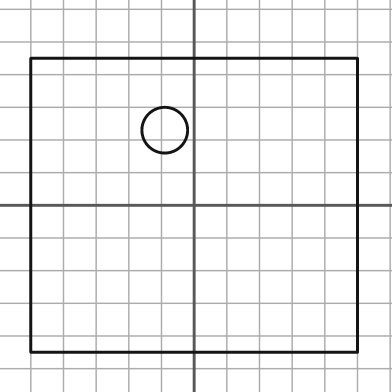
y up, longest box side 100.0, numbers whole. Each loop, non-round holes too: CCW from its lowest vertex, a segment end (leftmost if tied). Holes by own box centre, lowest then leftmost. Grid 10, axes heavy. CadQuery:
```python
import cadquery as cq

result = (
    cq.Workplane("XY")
    .moveTo(-50.0, -45.0)
    .lineTo(50.0, -45.0)
    .lineTo(50.0, 45.0)
    .lineTo(-50.0, 45.0)
    .close()
    .moveTo(-9.0, 23.0)
    .circle(7.0)
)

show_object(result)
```